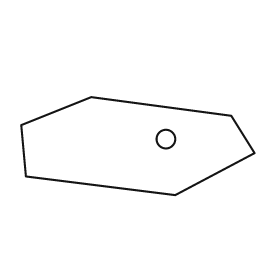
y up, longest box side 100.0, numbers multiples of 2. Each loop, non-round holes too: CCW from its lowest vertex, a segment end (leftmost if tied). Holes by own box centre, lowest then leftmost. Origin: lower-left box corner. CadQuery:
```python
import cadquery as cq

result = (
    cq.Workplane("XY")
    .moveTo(66.0, 0.0)
    .lineTo(100.0, 18.0)
    .lineTo(90.0, 34.0)
    .lineTo(30.0, 42.0)
    .lineTo(0.0, 30.0)
    .lineTo(2.0, 8.0)
    .close()
    .moveTo(62.0, 24.0)
    .circle(4.0)
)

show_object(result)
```